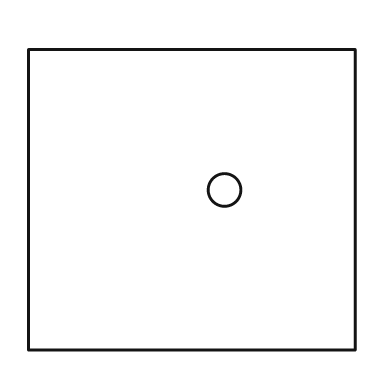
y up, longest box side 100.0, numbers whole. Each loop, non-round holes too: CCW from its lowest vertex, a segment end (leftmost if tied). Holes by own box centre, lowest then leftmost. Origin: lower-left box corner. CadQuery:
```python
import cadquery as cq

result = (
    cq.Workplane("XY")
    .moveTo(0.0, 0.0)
    .lineTo(100.0, 0.0)
    .lineTo(100.0, 92.0)
    .lineTo(0.0, 92.0)
    .close()
    .moveTo(60.0, 49.0)
    .circle(5.0)
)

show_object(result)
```